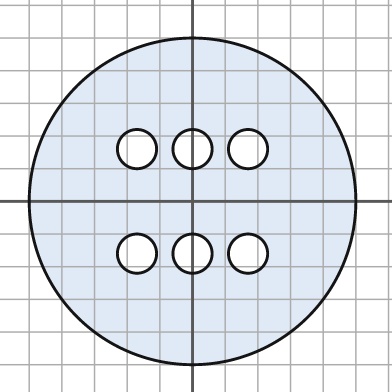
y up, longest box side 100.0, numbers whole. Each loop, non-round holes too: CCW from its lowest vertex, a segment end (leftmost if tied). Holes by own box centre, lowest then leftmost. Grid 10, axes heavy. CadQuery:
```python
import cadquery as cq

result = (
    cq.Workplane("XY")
    .moveTo(0.0, 0.0)
    .circle(50.0)
    .moveTo(-17.0, -16.0)
    .circle(6.0)
    .moveTo(0.0, -16.0)
    .circle(6.0)
    .moveTo(17.0, -16.0)
    .circle(6.0)
    .moveTo(-17.0, 16.0)
    .circle(6.0)
    .moveTo(0.0, 16.0)
    .circle(6.0)
    .moveTo(17.0, 16.0)
    .circle(6.0)
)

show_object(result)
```